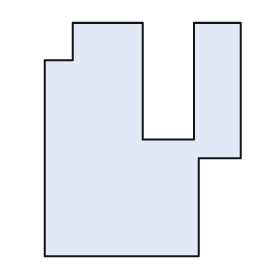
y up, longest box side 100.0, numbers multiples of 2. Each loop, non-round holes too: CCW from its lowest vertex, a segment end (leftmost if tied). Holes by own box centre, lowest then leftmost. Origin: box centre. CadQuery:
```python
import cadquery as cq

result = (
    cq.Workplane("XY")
    .moveTo(-42.0, -50.0)
    .lineTo(24.0, -50.0)
    .lineTo(24.0, -8.0)
    .lineTo(42.0, -8.0)
    .lineTo(42.0, 50.0)
    .lineTo(22.0, 50.0)
    .lineTo(22.0, 0.0)
    .lineTo(0.0, 0.0)
    .lineTo(0.0, 50.0)
    .lineTo(-30.0, 50.0)
    .lineTo(-30.0, 34.0)
    .lineTo(-42.0, 34.0)
    .close()
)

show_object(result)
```